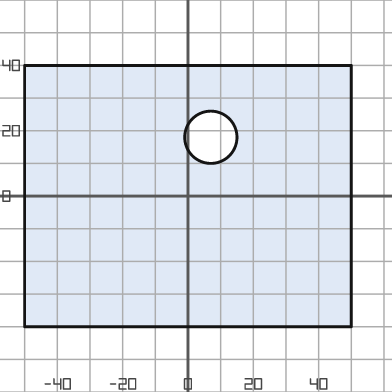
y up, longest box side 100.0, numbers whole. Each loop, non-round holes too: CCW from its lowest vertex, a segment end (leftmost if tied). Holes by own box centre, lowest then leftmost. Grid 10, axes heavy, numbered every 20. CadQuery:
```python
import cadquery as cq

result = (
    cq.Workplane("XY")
    .moveTo(-50.0, -40.0)
    .lineTo(50.0, -40.0)
    .lineTo(50.0, 40.0)
    .lineTo(-50.0, 40.0)
    .close()
    .moveTo(7.0, 18.0)
    .circle(8.0)
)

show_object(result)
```